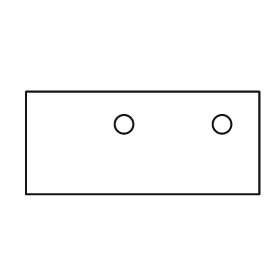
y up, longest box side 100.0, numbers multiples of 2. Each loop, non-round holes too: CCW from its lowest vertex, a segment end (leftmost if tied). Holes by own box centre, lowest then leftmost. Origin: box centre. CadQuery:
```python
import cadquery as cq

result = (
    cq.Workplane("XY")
    .moveTo(-50.0, -22.0)
    .lineTo(50.0, -22.0)
    .lineTo(50.0, 22.0)
    .lineTo(-50.0, 22.0)
    .close()
    .moveTo(-8.0, 8.0)
    .circle(4.0)
    .moveTo(34.0, 8.0)
    .circle(4.0)
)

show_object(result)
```